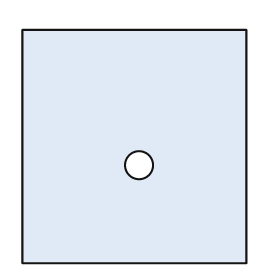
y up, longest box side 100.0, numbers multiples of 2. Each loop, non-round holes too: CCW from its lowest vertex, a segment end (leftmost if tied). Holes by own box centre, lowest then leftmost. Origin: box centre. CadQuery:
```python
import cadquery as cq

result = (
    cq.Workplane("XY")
    .moveTo(-48.0, -50.0)
    .lineTo(48.0, -50.0)
    .lineTo(48.0, 50.0)
    .lineTo(-48.0, 50.0)
    .close()
    .moveTo(2.0, -8.0)
    .circle(6.0)
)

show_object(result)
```